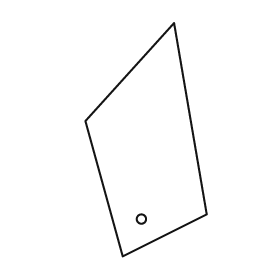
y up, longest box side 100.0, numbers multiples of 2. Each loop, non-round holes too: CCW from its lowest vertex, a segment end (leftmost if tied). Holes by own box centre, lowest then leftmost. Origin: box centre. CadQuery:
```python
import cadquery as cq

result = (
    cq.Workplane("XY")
    .moveTo(-10.0, -50.0)
    .lineTo(26.0, -32.0)
    .lineTo(12.0, 50.0)
    .lineTo(-26.0, 8.0)
    .close()
    .moveTo(-2.0, -34.0)
    .circle(2.0)
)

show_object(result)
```